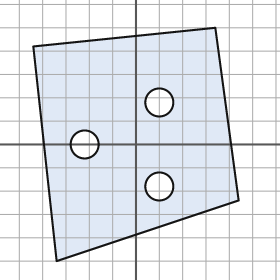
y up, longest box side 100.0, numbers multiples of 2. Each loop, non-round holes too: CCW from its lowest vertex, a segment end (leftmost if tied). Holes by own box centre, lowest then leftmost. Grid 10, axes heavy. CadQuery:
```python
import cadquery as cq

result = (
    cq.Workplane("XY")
    .moveTo(-34.0, -50.0)
    .lineTo(44.0, -24.0)
    .lineTo(34.0, 50.0)
    .lineTo(-44.0, 42.0)
    .close()
    .moveTo(10.0, -18.0)
    .circle(6.0)
    .moveTo(-22.0, 0.0)
    .circle(6.0)
    .moveTo(10.0, 18.0)
    .circle(6.0)
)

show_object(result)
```